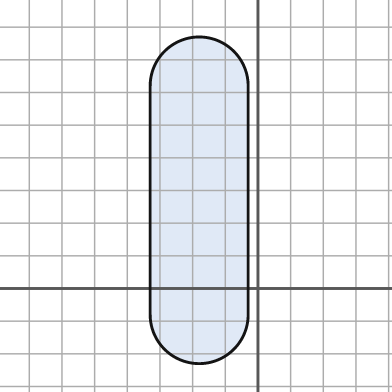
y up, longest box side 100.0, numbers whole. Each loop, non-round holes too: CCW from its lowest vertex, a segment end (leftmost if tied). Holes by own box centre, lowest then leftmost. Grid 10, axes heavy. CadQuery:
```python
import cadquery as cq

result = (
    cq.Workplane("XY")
    .moveTo(-33.0, -8.0)
    .threePointArc((-18.0, -23.0), (-3.0, -8.0))
    .lineTo(-3.0, 62.0)
    .threePointArc((-18.0, 77.0), (-33.0, 62.0))
    .close()
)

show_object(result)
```